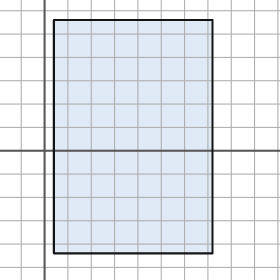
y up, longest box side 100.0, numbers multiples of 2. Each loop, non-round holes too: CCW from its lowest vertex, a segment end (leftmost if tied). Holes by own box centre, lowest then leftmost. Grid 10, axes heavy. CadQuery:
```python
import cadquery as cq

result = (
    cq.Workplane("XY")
    .moveTo(4.0, -44.0)
    .lineTo(72.0, -44.0)
    .lineTo(72.0, 56.0)
    .lineTo(4.0, 56.0)
    .close()
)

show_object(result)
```